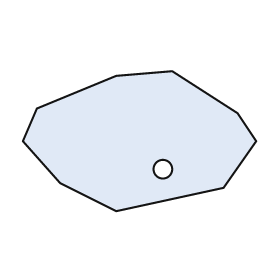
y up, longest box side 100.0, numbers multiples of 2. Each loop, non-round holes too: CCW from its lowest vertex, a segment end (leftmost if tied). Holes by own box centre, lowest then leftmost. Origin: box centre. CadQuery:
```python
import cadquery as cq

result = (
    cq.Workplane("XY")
    .moveTo(-10.0, -30.0)
    .lineTo(36.0, -20.0)
    .lineTo(50.0, 0.0)
    .lineTo(42.0, 12.0)
    .lineTo(14.0, 30.0)
    .lineTo(-10.0, 28.0)
    .lineTo(-44.0, 14.0)
    .lineTo(-50.0, 0.0)
    .lineTo(-34.0, -18.0)
    .close()
    .moveTo(10.0, -12.0)
    .circle(4.0)
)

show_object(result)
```